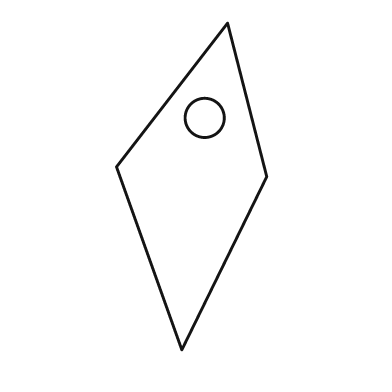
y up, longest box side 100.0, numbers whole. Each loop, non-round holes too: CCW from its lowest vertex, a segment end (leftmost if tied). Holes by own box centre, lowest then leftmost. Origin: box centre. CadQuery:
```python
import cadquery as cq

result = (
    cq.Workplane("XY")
    .moveTo(-3.0, -50.0)
    .lineTo(23.0, 3.0)
    .lineTo(11.0, 50.0)
    .lineTo(-23.0, 6.0)
    .close()
    .moveTo(4.0, 21.0)
    .circle(6.0)
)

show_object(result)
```